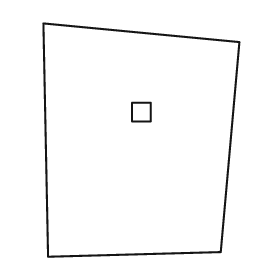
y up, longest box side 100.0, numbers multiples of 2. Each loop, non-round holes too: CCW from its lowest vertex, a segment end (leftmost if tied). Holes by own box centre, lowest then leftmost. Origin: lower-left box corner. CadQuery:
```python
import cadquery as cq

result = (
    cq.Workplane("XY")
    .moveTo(2.0, 0.0)
    .lineTo(76.0, 2.0)
    .lineTo(84.0, 92.0)
    .lineTo(0.0, 100.0)
    .close()
    .moveTo(38.0, 58.0)
    .lineTo(46.0, 58.0)
    .lineTo(46.0, 66.0)
    .lineTo(38.0, 66.0)
    .close()
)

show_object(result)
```